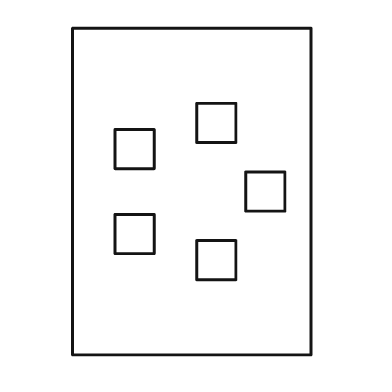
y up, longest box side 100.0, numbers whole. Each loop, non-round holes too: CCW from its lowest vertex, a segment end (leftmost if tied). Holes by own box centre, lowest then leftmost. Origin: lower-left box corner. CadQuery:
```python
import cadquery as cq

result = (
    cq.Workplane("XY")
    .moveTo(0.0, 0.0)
    .lineTo(73.0, 0.0)
    .lineTo(73.0, 100.0)
    .lineTo(0.0, 100.0)
    .close()
    .moveTo(38.0, 23.0)
    .lineTo(50.0, 23.0)
    .lineTo(50.0, 35.0)
    .lineTo(38.0, 35.0)
    .close()
    .moveTo(13.0, 31.0)
    .lineTo(25.0, 31.0)
    .lineTo(25.0, 43.0)
    .lineTo(13.0, 43.0)
    .close()
    .moveTo(53.0, 44.0)
    .lineTo(65.0, 44.0)
    .lineTo(65.0, 56.0)
    .lineTo(53.0, 56.0)
    .close()
    .moveTo(13.0, 57.0)
    .lineTo(25.0, 57.0)
    .lineTo(25.0, 69.0)
    .lineTo(13.0, 69.0)
    .close()
    .moveTo(38.0, 65.0)
    .lineTo(50.0, 65.0)
    .lineTo(50.0, 77.0)
    .lineTo(38.0, 77.0)
    .close()
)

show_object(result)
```